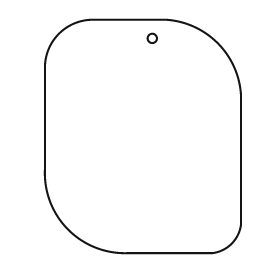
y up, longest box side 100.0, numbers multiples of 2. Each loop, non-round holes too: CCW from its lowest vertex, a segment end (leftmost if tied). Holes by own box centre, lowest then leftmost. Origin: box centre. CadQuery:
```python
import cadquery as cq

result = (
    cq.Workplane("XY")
    .moveTo(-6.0, -50.0)
    .lineTo(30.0, -50.0)
    .threePointArc((38.0, -46.0), (42.0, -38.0))
    .lineTo(42.0, 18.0)
    .threePointArc((32.0, 40.0), (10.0, 50.0))
    .lineTo(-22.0, 50.0)
    .threePointArc((-36.0, 44.0), (-42.0, 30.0))
    .lineTo(-42.0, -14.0)
    .threePointArc((-32.0, -40.0), (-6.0, -50.0))
    .close()
    .moveTo(4.0, 42.0)
    .circle(2.0)
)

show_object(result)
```